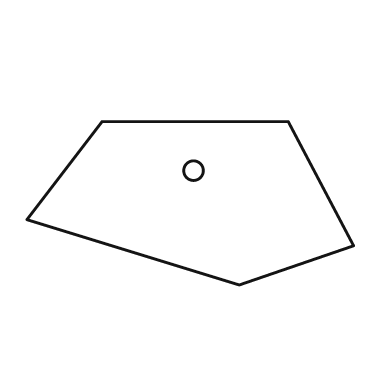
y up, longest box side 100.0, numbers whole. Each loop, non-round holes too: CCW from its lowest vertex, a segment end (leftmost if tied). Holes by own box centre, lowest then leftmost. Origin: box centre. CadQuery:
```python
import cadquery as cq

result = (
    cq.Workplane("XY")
    .moveTo(15.0, -25.0)
    .lineTo(50.0, -13.0)
    .lineTo(30.0, 25.0)
    .lineTo(-27.0, 25.0)
    .lineTo(-50.0, -5.0)
    .close()
    .moveTo(1.0, 10.0)
    .circle(3.0)
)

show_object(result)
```